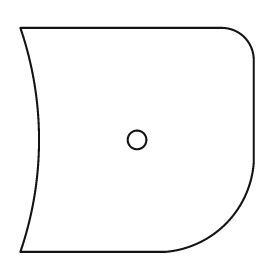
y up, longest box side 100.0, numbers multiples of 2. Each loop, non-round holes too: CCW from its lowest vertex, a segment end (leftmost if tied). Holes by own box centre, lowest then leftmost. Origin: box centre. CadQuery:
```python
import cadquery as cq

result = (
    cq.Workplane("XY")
    .moveTo(-50.0, -48.0)
    .lineTo(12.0, -48.0)
    .threePointArc((38.0, -36.0), (50.0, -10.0))
    .lineTo(50.0, 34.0)
    .threePointArc((46.0, 44.0), (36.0, 48.0))
    .lineTo(-50.0, 48.0)
    .threePointArc((-42.0, 0.0), (-50.0, -48.0))
    .close()
    .moveTo(0.0, 0.0)
    .circle(4.0)
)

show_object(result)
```